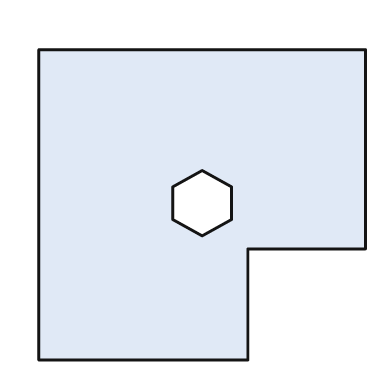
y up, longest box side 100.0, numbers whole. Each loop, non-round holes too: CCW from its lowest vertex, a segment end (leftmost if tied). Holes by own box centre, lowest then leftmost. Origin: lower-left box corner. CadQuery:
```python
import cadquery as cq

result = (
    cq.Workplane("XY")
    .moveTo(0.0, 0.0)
    .lineTo(64.0, 0.0)
    .lineTo(64.0, 34.0)
    .lineTo(100.0, 34.0)
    .lineTo(100.0, 95.0)
    .lineTo(0.0, 95.0)
    .close()
    .moveTo(50.0, 38.0)
    .lineTo(59.0, 43.0)
    .lineTo(59.0, 53.0)
    .lineTo(50.0, 58.0)
    .lineTo(41.0, 53.0)
    .lineTo(41.0, 43.0)
    .close()
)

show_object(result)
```